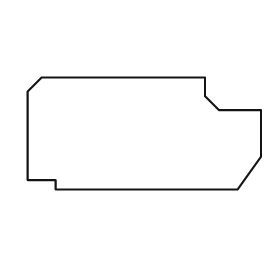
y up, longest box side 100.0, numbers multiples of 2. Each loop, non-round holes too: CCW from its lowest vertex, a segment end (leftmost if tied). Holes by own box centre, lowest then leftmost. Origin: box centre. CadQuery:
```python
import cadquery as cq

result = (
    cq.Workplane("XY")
    .moveTo(-38.0, -24.0)
    .lineTo(40.0, -24.0)
    .lineTo(50.0, -10.0)
    .lineTo(50.0, 10.0)
    .lineTo(32.0, 10.0)
    .lineTo(26.0, 16.0)
    .lineTo(26.0, 24.0)
    .lineTo(-44.0, 24.0)
    .lineTo(-50.0, 18.0)
    .lineTo(-50.0, -20.0)
    .lineTo(-38.0, -20.0)
    .close()
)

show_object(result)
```